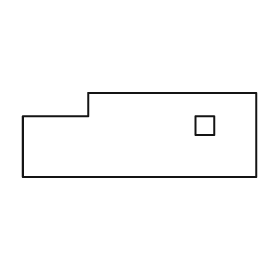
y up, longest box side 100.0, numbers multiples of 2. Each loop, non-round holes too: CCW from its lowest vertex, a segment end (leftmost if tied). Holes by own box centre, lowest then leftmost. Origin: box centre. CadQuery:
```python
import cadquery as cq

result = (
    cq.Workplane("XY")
    .moveTo(-50.0, -18.0)
    .lineTo(50.0, -18.0)
    .lineTo(50.0, 18.0)
    .lineTo(-22.0, 18.0)
    .lineTo(-22.0, 8.0)
    .lineTo(-50.0, 8.0)
    .close()
    .moveTo(24.0, 0.0)
    .lineTo(32.0, 0.0)
    .lineTo(32.0, 8.0)
    .lineTo(24.0, 8.0)
    .close()
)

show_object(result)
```